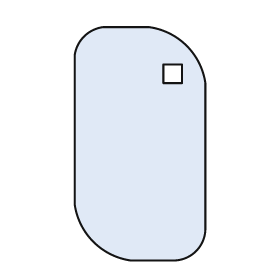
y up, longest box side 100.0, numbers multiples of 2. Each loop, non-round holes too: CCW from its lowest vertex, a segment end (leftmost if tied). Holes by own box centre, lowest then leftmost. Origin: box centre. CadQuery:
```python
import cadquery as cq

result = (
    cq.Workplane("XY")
    .moveTo(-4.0, -50.0)
    .lineTo(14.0, -50.0)
    .threePointArc((24.0, -46.0), (28.0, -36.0))
    .lineTo(28.0, 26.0)
    .threePointArc((20.0, 42.0), (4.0, 50.0))
    .lineTo(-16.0, 50.0)
    .threePointArc((-24.0, 46.0), (-28.0, 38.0))
    .lineTo(-28.0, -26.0)
    .threePointArc((-20.0, -42.0), (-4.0, -50.0))
    .close()
    .moveTo(10.0, 26.0)
    .lineTo(18.0, 26.0)
    .lineTo(18.0, 34.0)
    .lineTo(10.0, 34.0)
    .close()
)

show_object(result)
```